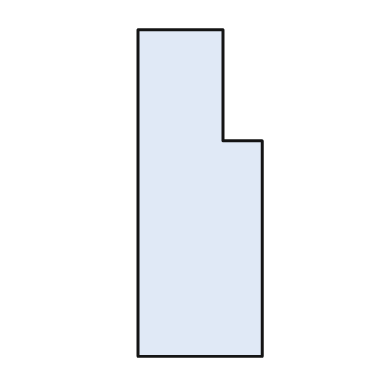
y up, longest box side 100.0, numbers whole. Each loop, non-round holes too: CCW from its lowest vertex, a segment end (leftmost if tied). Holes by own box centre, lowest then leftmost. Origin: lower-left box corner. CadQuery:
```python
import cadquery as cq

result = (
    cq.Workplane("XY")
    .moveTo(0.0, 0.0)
    .lineTo(38.0, 0.0)
    .lineTo(38.0, 66.0)
    .lineTo(26.0, 66.0)
    .lineTo(26.0, 100.0)
    .lineTo(0.0, 100.0)
    .close()
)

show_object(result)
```